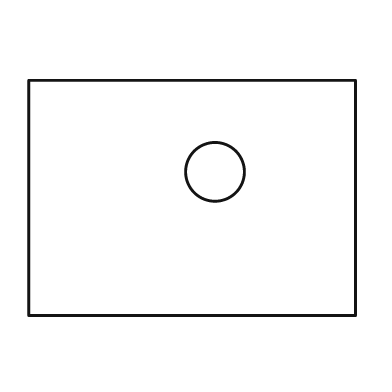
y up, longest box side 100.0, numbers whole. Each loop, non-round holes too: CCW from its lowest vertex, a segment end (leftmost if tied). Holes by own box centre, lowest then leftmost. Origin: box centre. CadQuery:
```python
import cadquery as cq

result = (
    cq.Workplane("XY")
    .moveTo(-50.0, -36.0)
    .lineTo(50.0, -36.0)
    .lineTo(50.0, 36.0)
    .lineTo(-50.0, 36.0)
    .close()
    .moveTo(7.0, 8.0)
    .circle(9.0)
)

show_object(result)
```